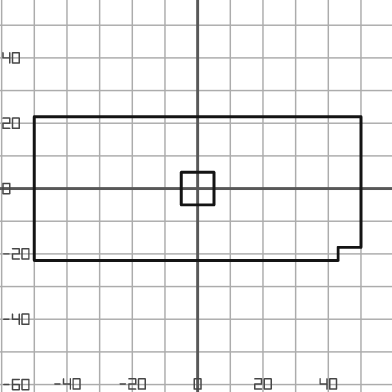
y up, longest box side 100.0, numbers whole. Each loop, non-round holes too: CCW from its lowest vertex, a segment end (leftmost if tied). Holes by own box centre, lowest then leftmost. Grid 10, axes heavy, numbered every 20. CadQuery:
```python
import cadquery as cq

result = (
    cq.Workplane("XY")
    .moveTo(-50.0, -22.0)
    .lineTo(43.0, -22.0)
    .lineTo(43.0, -18.0)
    .lineTo(50.0, -18.0)
    .lineTo(50.0, 22.0)
    .lineTo(-50.0, 22.0)
    .close()
    .moveTo(-5.0, -5.0)
    .lineTo(5.0, -5.0)
    .lineTo(5.0, 5.0)
    .lineTo(-5.0, 5.0)
    .close()
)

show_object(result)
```